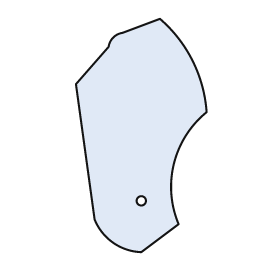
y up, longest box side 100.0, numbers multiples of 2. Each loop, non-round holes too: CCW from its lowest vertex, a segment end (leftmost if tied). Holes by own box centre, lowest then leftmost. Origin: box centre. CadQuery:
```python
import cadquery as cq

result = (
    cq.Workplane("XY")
    .moveTo(0.0, -50.0)
    .lineTo(16.0, -38.0)
    .threePointArc((14.0, -12.0), (28.0, 10.0))
    .threePointArc((22.0, 32.0), (8.0, 50.0))
    .lineTo(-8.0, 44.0)
    .threePointArc((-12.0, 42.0), (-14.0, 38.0))
    .lineTo(-28.0, 22.0)
    .lineTo(-20.0, -36.0)
    .threePointArc((-12.0, -46.0), (0.0, -50.0))
    .close()
    .moveTo(0.0, -28.0)
    .circle(2.0)
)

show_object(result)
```